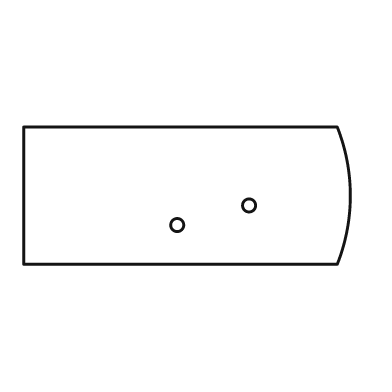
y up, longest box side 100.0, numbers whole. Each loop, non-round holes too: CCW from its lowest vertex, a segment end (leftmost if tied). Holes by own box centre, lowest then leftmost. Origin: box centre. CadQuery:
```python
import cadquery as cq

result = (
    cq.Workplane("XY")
    .moveTo(-50.0, -21.0)
    .lineTo(46.0, -21.0)
    .threePointArc((50.0, 0.0), (46.0, 21.0))
    .lineTo(-50.0, 21.0)
    .close()
    .moveTo(-3.0, -9.0)
    .circle(2.0)
    .moveTo(19.0, -3.0)
    .circle(2.0)
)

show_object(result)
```